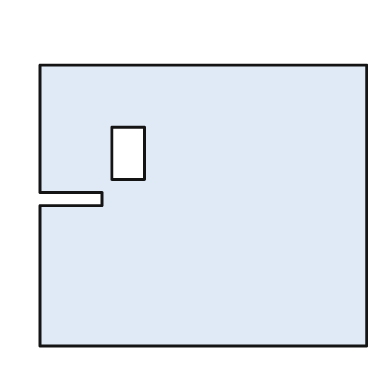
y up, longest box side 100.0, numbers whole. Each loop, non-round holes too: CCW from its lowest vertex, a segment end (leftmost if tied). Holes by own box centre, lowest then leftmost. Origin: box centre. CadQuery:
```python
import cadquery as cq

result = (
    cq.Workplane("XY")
    .moveTo(-50.0, -43.0)
    .lineTo(50.0, -43.0)
    .lineTo(50.0, 43.0)
    .lineTo(-50.0, 43.0)
    .lineTo(-50.0, 4.0)
    .lineTo(-31.0, 4.0)
    .lineTo(-31.0, 0.0)
    .lineTo(-50.0, 0.0)
    .close()
    .moveTo(-28.0, 8.0)
    .lineTo(-18.0, 8.0)
    .lineTo(-18.0, 24.0)
    .lineTo(-28.0, 24.0)
    .close()
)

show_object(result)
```